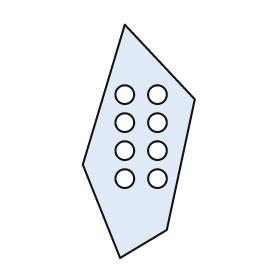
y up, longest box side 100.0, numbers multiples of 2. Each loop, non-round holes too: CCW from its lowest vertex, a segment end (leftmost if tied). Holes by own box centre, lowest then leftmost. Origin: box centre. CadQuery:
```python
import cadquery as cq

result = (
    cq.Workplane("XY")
    .moveTo(-8.0, -50.0)
    .lineTo(12.0, -38.0)
    .lineTo(24.0, 18.0)
    .lineTo(-6.0, 50.0)
    .lineTo(-24.0, -10.0)
    .close()
    .moveTo(-6.0, -16.0)
    .circle(4.0)
    .moveTo(8.0, -16.0)
    .circle(4.0)
    .moveTo(-6.0, -4.0)
    .circle(4.0)
    .moveTo(8.0, -4.0)
    .circle(4.0)
    .moveTo(-6.0, 8.0)
    .circle(4.0)
    .moveTo(8.0, 8.0)
    .circle(4.0)
    .moveTo(-6.0, 20.0)
    .circle(4.0)
    .moveTo(8.0, 20.0)
    .circle(4.0)
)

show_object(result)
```